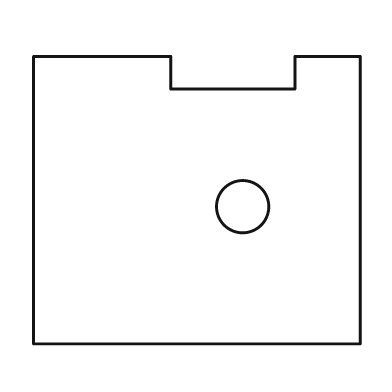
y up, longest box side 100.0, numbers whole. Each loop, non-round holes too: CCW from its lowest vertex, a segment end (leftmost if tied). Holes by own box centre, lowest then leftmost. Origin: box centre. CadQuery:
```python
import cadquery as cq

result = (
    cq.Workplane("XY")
    .moveTo(-50.0, -44.0)
    .lineTo(50.0, -44.0)
    .lineTo(50.0, 44.0)
    .lineTo(30.0, 44.0)
    .lineTo(30.0, 34.0)
    .lineTo(-8.0, 34.0)
    .lineTo(-8.0, 44.0)
    .lineTo(-50.0, 44.0)
    .close()
    .moveTo(14.0, -2.0)
    .circle(8.0)
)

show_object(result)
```